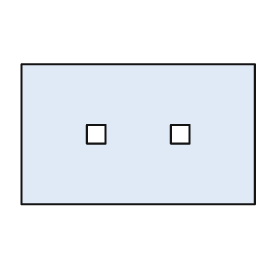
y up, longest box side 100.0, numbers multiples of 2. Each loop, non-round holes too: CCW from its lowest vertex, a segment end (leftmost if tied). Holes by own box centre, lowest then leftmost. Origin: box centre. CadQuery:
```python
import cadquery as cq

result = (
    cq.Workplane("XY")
    .moveTo(-50.0, -30.0)
    .lineTo(50.0, -30.0)
    .lineTo(50.0, 30.0)
    .lineTo(-50.0, 30.0)
    .close()
    .moveTo(-22.0, -4.0)
    .lineTo(-14.0, -4.0)
    .lineTo(-14.0, 4.0)
    .lineTo(-22.0, 4.0)
    .close()
    .moveTo(14.0, -4.0)
    .lineTo(22.0, -4.0)
    .lineTo(22.0, 4.0)
    .lineTo(14.0, 4.0)
    .close()
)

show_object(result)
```